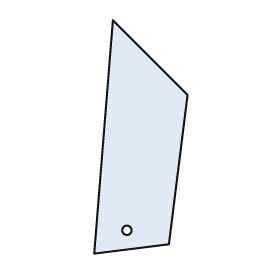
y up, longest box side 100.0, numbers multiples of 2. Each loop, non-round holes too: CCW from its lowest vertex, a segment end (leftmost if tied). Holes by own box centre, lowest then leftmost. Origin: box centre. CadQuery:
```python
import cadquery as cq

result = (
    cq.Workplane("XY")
    .moveTo(-20.0, -50.0)
    .lineTo(12.0, -46.0)
    .lineTo(20.0, 18.0)
    .lineTo(-12.0, 50.0)
    .close()
    .moveTo(-6.0, -40.0)
    .circle(2.0)
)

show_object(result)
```